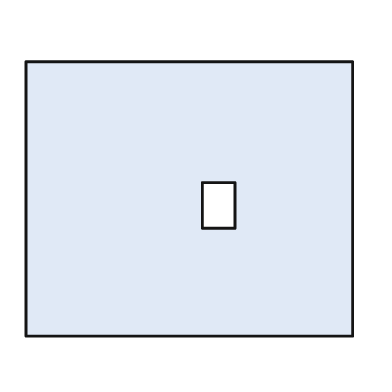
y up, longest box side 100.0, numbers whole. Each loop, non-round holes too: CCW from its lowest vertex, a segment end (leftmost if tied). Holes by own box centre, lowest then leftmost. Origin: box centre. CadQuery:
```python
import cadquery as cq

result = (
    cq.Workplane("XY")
    .moveTo(-50.0, -42.0)
    .lineTo(50.0, -42.0)
    .lineTo(50.0, 42.0)
    .lineTo(-50.0, 42.0)
    .close()
    .moveTo(4.0, -9.0)
    .lineTo(14.0, -9.0)
    .lineTo(14.0, 5.0)
    .lineTo(4.0, 5.0)
    .close()
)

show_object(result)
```